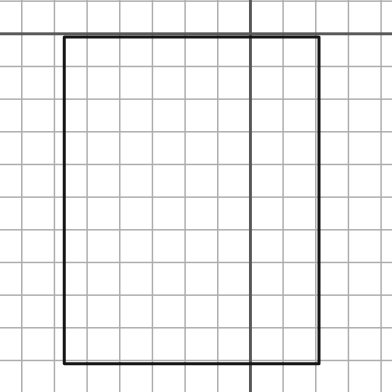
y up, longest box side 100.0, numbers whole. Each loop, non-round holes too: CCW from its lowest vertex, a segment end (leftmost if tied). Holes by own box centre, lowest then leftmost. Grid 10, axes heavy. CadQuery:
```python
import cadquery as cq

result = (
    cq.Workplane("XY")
    .moveTo(-57.0, -101.0)
    .lineTo(21.0, -101.0)
    .lineTo(21.0, -1.0)
    .lineTo(-57.0, -1.0)
    .close()
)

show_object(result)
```